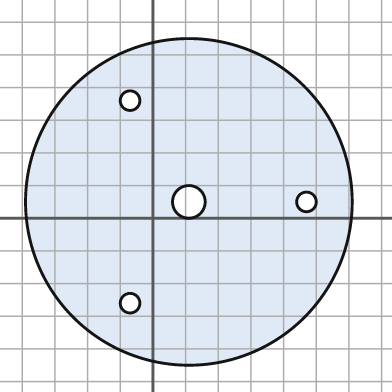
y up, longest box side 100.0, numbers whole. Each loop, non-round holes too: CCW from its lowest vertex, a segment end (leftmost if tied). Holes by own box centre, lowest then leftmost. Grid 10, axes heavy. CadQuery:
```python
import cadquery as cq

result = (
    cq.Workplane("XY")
    .moveTo(11.0, 5.0)
    .circle(50.0)
    .moveTo(-7.0, -26.0)
    .circle(3.0)
    .moveTo(11.0, 5.0)
    .circle(5.0)
    .moveTo(47.0, 5.0)
    .circle(3.0)
    .moveTo(-7.0, 36.0)
    .circle(3.0)
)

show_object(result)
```